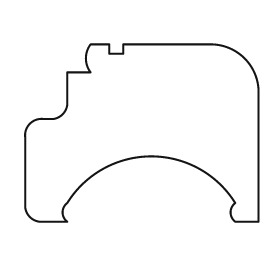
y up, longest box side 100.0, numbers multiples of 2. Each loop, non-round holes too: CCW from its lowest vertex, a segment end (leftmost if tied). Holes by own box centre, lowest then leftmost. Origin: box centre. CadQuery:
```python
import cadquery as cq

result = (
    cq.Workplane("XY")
    .moveTo(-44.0, -38.0)
    .lineTo(-32.0, -38.0)
    .threePointArc((-34.0, -34.0), (-32.0, -30.0))
    .threePointArc((4.0, -10.0), (40.0, -30.0))
    .threePointArc((38.0, -34.0), (40.0, -38.0))
    .lineTo(50.0, -38.0)
    .lineTo(50.0, 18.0)
    .threePointArc((44.0, 32.0), (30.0, 38.0))
    .lineTo(-8.0, 38.0)
    .lineTo(-8.0, 34.0)
    .lineTo(-14.0, 34.0)
    .lineTo(-14.0, 38.0)
    .lineTo(-22.0, 38.0)
    .threePointArc((-24.0, 32.0), (-22.0, 26.0))
    .lineTo(-32.0, 26.0)
    .lineTo(-32.0, 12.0)
    .threePointArc((-34.0, 8.0), (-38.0, 6.0))
    .lineTo(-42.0, 6.0)
    .threePointArc((-48.0, 4.0), (-50.0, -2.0))
    .lineTo(-50.0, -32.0)
    .threePointArc((-48.0, -36.0), (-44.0, -38.0))
    .close()
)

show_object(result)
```